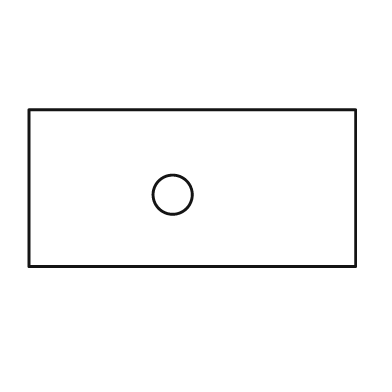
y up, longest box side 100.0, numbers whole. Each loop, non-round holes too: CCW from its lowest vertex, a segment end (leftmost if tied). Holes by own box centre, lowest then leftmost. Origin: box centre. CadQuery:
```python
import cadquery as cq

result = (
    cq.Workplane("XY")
    .moveTo(-50.0, -24.0)
    .lineTo(50.0, -24.0)
    .lineTo(50.0, 24.0)
    .lineTo(-50.0, 24.0)
    .close()
    .moveTo(-6.0, -2.0)
    .circle(6.0)
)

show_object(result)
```